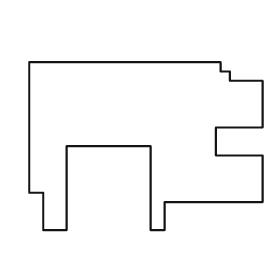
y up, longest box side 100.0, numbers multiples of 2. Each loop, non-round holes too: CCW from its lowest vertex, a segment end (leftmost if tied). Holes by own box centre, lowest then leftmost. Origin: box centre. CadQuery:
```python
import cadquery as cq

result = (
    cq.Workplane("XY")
    .moveTo(-44.0, -36.0)
    .lineTo(-34.0, -36.0)
    .lineTo(-34.0, 0.0)
    .lineTo(2.0, 0.0)
    .lineTo(2.0, -36.0)
    .lineTo(8.0, -36.0)
    .lineTo(8.0, -24.0)
    .lineTo(50.0, -24.0)
    .lineTo(50.0, -4.0)
    .lineTo(30.0, -4.0)
    .lineTo(30.0, 8.0)
    .lineTo(50.0, 8.0)
    .lineTo(50.0, 28.0)
    .lineTo(36.0, 28.0)
    .lineTo(36.0, 32.0)
    .lineTo(32.0, 32.0)
    .lineTo(32.0, 36.0)
    .lineTo(-50.0, 36.0)
    .lineTo(-50.0, -20.0)
    .lineTo(-44.0, -20.0)
    .close()
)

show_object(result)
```